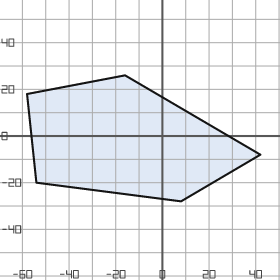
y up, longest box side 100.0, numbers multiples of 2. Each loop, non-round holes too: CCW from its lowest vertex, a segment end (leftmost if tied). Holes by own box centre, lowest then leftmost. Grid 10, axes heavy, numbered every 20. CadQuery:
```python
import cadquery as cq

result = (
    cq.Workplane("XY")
    .moveTo(8.0, -28.0)
    .lineTo(42.0, -8.0)
    .lineTo(-16.0, 26.0)
    .lineTo(-58.0, 18.0)
    .lineTo(-54.0, -20.0)
    .close()
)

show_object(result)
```